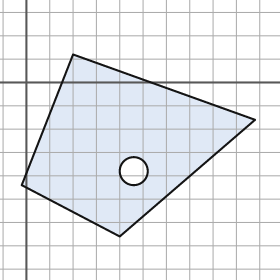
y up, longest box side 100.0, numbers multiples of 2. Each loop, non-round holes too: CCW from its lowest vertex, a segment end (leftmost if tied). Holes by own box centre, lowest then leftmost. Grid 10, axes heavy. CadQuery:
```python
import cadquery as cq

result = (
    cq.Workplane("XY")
    .moveTo(40.0, -66.0)
    .lineTo(98.0, -16.0)
    .lineTo(20.0, 12.0)
    .lineTo(-2.0, -44.0)
    .close()
    .moveTo(46.0, -38.0)
    .circle(6.0)
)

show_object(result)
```